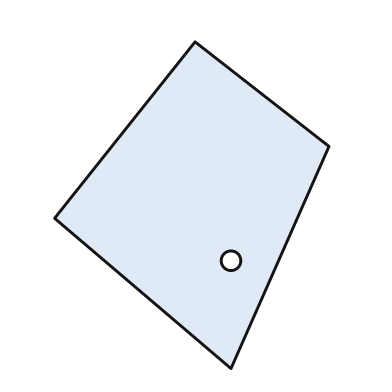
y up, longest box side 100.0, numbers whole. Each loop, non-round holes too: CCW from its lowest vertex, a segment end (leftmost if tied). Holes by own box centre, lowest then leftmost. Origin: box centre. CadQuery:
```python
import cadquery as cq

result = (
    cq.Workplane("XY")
    .moveTo(12.0, -50.0)
    .lineTo(42.0, 18.0)
    .lineTo(1.0, 50.0)
    .lineTo(-42.0, -4.0)
    .close()
    .moveTo(12.0, -17.0)
    .circle(3.0)
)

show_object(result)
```